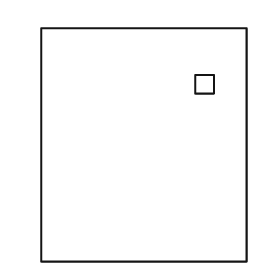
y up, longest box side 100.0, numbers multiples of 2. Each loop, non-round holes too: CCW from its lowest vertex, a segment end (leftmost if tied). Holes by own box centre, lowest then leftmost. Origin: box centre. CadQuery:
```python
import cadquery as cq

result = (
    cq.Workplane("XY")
    .moveTo(-44.0, -50.0)
    .lineTo(44.0, -50.0)
    .lineTo(44.0, 50.0)
    .lineTo(-44.0, 50.0)
    .close()
    .moveTo(22.0, 22.0)
    .lineTo(30.0, 22.0)
    .lineTo(30.0, 30.0)
    .lineTo(22.0, 30.0)
    .close()
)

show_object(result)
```